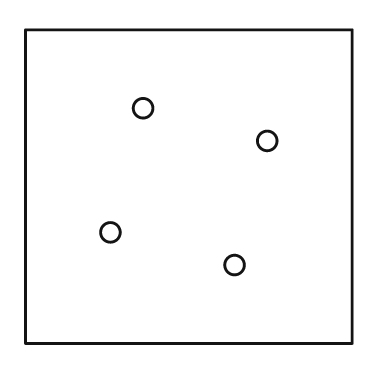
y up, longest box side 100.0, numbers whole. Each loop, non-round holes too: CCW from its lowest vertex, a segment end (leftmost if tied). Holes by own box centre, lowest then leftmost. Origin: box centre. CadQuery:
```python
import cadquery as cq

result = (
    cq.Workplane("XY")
    .moveTo(-50.0, -48.0)
    .lineTo(50.0, -48.0)
    .lineTo(50.0, 48.0)
    .lineTo(-50.0, 48.0)
    .close()
    .moveTo(14.0, -24.0)
    .circle(3.0)
    .moveTo(-24.0, -14.0)
    .circle(3.0)
    .moveTo(24.0, 14.0)
    .circle(3.0)
    .moveTo(-14.0, 24.0)
    .circle(3.0)
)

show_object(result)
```